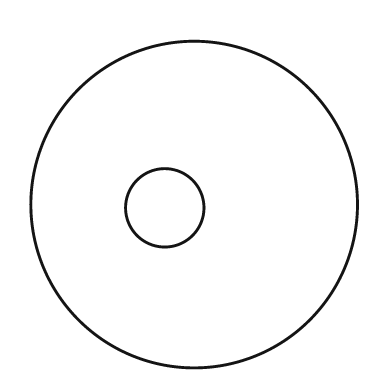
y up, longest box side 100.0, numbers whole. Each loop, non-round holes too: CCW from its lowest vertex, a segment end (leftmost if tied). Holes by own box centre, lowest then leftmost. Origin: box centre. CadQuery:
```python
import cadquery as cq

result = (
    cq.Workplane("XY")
    .moveTo(0.0, 0.0)
    .circle(50.0)
    .moveTo(-9.0, -1.0)
    .circle(12.0)
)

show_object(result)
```